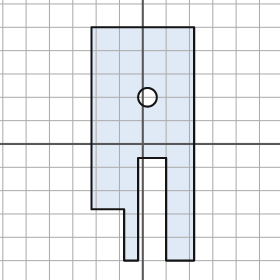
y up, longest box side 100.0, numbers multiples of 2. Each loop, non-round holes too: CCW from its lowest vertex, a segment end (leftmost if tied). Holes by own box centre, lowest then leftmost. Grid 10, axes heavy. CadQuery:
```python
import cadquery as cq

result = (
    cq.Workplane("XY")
    .moveTo(-8.0, -50.0)
    .lineTo(-2.0, -50.0)
    .lineTo(-2.0, -6.0)
    .lineTo(10.0, -6.0)
    .lineTo(10.0, -50.0)
    .lineTo(22.0, -50.0)
    .lineTo(22.0, 50.0)
    .lineTo(-22.0, 50.0)
    .lineTo(-22.0, -28.0)
    .lineTo(-8.0, -28.0)
    .close()
    .moveTo(2.0, 20.0)
    .circle(4.0)
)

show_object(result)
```